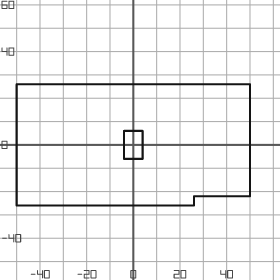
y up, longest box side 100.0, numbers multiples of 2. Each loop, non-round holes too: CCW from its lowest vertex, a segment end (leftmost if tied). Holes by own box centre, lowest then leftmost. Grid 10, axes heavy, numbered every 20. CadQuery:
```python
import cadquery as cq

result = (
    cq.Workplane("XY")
    .moveTo(-50.0, -26.0)
    .lineTo(26.0, -26.0)
    .lineTo(26.0, -22.0)
    .lineTo(50.0, -22.0)
    .lineTo(50.0, 26.0)
    .lineTo(-50.0, 26.0)
    .close()
    .moveTo(-4.0, -6.0)
    .lineTo(4.0, -6.0)
    .lineTo(4.0, 6.0)
    .lineTo(-4.0, 6.0)
    .close()
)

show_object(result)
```